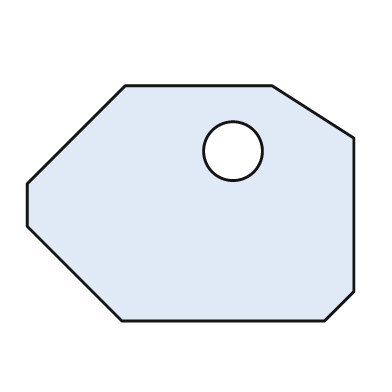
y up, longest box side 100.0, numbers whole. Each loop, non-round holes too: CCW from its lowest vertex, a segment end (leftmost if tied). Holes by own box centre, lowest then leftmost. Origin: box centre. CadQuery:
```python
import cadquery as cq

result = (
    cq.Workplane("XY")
    .moveTo(-21.0, -36.0)
    .lineTo(41.0, -36.0)
    .lineTo(50.0, -27.0)
    .lineTo(50.0, 20.0)
    .lineTo(25.0, 36.0)
    .lineTo(-20.0, 36.0)
    .lineTo(-50.0, 6.0)
    .lineTo(-50.0, -7.0)
    .close()
    .moveTo(13.0, 16.0)
    .circle(9.0)
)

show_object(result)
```